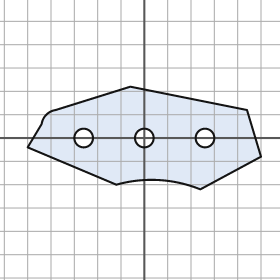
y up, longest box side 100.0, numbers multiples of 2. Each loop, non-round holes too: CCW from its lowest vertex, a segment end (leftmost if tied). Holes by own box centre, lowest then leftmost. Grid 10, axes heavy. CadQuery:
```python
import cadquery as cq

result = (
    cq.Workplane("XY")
    .moveTo(24.0, -22.0)
    .lineTo(50.0, -8.0)
    .lineTo(44.0, 12.0)
    .lineTo(-6.0, 22.0)
    .lineTo(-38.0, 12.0)
    .threePointArc((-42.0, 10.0), (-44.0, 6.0))
    .lineTo(-50.0, -4.0)
    .lineTo(-12.0, -20.0)
    .threePointArc((6.0, -18.0), (24.0, -22.0))
    .close()
    .moveTo(-26.0, 0.0)
    .circle(4.0)
    .moveTo(0.0, 0.0)
    .circle(4.0)
    .moveTo(26.0, 0.0)
    .circle(4.0)
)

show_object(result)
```